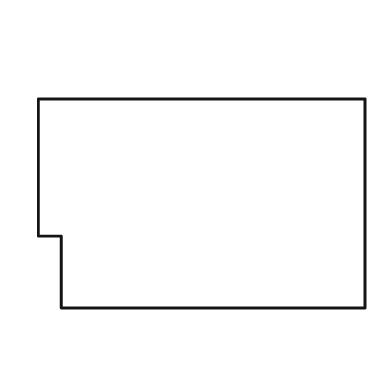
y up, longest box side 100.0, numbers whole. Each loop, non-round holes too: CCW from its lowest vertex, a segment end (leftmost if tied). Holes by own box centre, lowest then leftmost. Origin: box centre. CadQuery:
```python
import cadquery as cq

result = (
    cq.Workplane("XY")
    .moveTo(-43.0, -32.0)
    .lineTo(50.0, -32.0)
    .lineTo(50.0, 32.0)
    .lineTo(-50.0, 32.0)
    .lineTo(-50.0, -10.0)
    .lineTo(-43.0, -10.0)
    .close()
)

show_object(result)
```